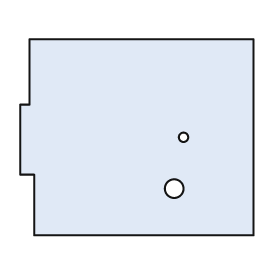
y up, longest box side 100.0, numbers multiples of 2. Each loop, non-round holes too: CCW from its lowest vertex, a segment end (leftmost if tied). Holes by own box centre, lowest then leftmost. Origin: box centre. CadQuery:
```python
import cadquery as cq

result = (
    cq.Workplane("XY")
    .moveTo(-44.0, -42.0)
    .lineTo(50.0, -42.0)
    .lineTo(50.0, 42.0)
    .lineTo(-46.0, 42.0)
    .lineTo(-46.0, 14.0)
    .lineTo(-50.0, 14.0)
    .lineTo(-50.0, -16.0)
    .lineTo(-44.0, -16.0)
    .close()
    .moveTo(16.0, -22.0)
    .circle(4.0)
    .moveTo(20.0, 0.0)
    .circle(2.0)
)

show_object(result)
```